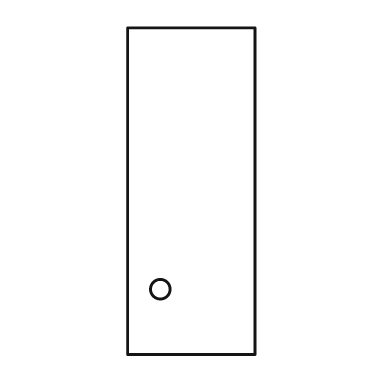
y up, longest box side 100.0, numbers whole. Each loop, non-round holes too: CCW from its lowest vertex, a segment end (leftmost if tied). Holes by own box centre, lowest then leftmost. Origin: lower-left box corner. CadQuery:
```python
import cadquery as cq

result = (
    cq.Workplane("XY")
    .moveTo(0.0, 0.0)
    .lineTo(39.0, 0.0)
    .lineTo(39.0, 100.0)
    .lineTo(0.0, 100.0)
    .close()
    .moveTo(10.0, 20.0)
    .circle(3.0)
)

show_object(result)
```